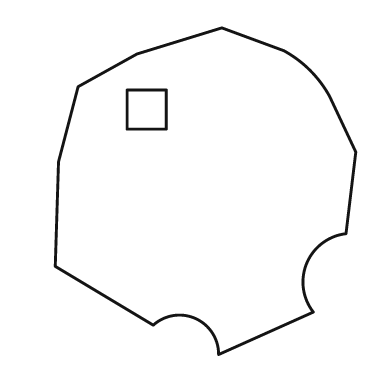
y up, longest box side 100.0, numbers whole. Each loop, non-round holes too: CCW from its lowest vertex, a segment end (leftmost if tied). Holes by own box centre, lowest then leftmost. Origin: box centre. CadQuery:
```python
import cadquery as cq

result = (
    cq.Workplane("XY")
    .moveTo(4.0, -50.0)
    .lineTo(33.0, -37.0)
    .threePointArc((31.0, -22.0), (43.0, -13.0))
    .lineTo(46.0, 12.0)
    .lineTo(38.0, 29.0)
    .threePointArc((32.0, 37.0), (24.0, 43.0))
    .lineTo(5.0, 50.0)
    .lineTo(-21.0, 42.0)
    .lineTo(-39.0, 32.0)
    .lineTo(-45.0, 9.0)
    .lineTo(-46.0, -23.0)
    .lineTo(-16.0, -41.0)
    .threePointArc((-3.0, -39.0), (4.0, -50.0))
    .close()
    .moveTo(-24.0, 19.0)
    .lineTo(-12.0, 19.0)
    .lineTo(-12.0, 31.0)
    .lineTo(-24.0, 31.0)
    .close()
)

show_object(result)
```